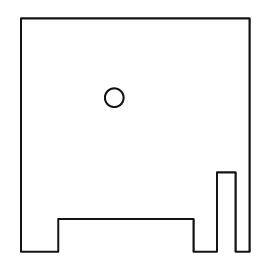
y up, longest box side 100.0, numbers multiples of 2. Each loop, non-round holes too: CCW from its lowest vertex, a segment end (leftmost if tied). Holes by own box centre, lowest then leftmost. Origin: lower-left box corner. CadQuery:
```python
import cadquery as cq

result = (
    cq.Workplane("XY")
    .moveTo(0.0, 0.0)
    .lineTo(16.0, 0.0)
    .lineTo(16.0, 14.0)
    .lineTo(74.0, 14.0)
    .lineTo(74.0, 0.0)
    .lineTo(84.0, 0.0)
    .lineTo(84.0, 34.0)
    .lineTo(92.0, 34.0)
    .lineTo(92.0, 0.0)
    .lineTo(98.0, 0.0)
    .lineTo(98.0, 100.0)
    .lineTo(0.0, 100.0)
    .close()
    .moveTo(40.0, 66.0)
    .circle(4.0)
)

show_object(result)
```